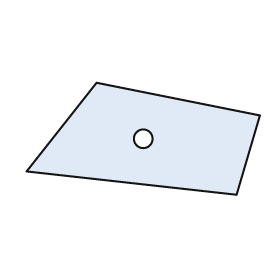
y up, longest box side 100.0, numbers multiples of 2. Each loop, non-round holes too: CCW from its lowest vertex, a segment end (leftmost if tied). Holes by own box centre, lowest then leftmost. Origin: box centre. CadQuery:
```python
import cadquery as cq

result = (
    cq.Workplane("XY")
    .moveTo(40.0, -24.0)
    .lineTo(50.0, 10.0)
    .lineTo(-20.0, 24.0)
    .lineTo(-50.0, -14.0)
    .close()
    .moveTo(0.0, 0.0)
    .circle(4.0)
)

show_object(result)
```